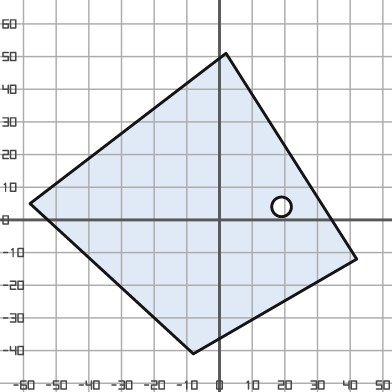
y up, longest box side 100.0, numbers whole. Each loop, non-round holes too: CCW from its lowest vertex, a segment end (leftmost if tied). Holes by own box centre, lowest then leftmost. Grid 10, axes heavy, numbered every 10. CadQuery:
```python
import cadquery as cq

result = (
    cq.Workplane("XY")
    .moveTo(-8.0, -41.0)
    .lineTo(42.0, -12.0)
    .lineTo(2.0, 51.0)
    .lineTo(-58.0, 5.0)
    .close()
    .moveTo(19.0, 4.0)
    .circle(3.0)
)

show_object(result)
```